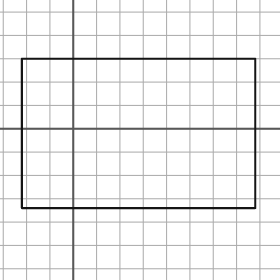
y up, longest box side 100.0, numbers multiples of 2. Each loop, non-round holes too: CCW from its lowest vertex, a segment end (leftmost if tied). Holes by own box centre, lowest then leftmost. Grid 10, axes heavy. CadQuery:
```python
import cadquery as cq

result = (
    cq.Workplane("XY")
    .moveTo(-22.0, -34.0)
    .lineTo(78.0, -34.0)
    .lineTo(78.0, 30.0)
    .lineTo(-22.0, 30.0)
    .close()
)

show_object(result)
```